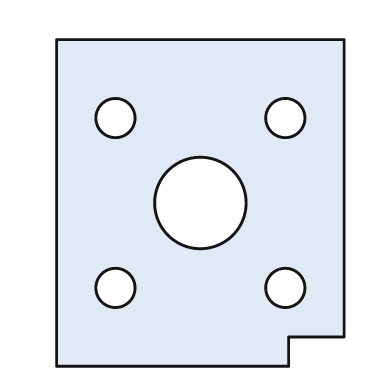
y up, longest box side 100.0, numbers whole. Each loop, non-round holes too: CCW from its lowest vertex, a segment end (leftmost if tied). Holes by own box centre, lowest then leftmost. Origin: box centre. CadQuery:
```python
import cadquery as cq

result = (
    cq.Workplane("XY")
    .moveTo(-44.0, -50.0)
    .lineTo(27.0, -50.0)
    .lineTo(27.0, -41.0)
    .lineTo(44.0, -41.0)
    .lineTo(44.0, 50.0)
    .lineTo(-44.0, 50.0)
    .close()
    .moveTo(-26.0, -26.0)
    .circle(6.0)
    .moveTo(26.0, -26.0)
    .circle(6.0)
    .moveTo(0.0, 0.0)
    .circle(14.0)
    .moveTo(-26.0, 26.0)
    .circle(6.0)
    .moveTo(26.0, 26.0)
    .circle(6.0)
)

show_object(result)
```